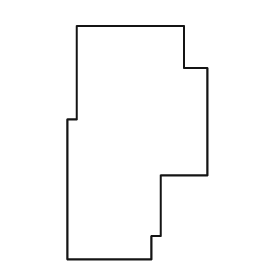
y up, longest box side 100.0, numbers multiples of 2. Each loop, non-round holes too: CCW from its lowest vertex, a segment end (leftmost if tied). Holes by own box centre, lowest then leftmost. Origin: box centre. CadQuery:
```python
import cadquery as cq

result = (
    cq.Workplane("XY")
    .moveTo(-30.0, -50.0)
    .lineTo(6.0, -50.0)
    .lineTo(6.0, -40.0)
    .lineTo(10.0, -40.0)
    .lineTo(10.0, -14.0)
    .lineTo(30.0, -14.0)
    .lineTo(30.0, 32.0)
    .lineTo(20.0, 32.0)
    .lineTo(20.0, 50.0)
    .lineTo(-26.0, 50.0)
    .lineTo(-26.0, 10.0)
    .lineTo(-30.0, 10.0)
    .close()
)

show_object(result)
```